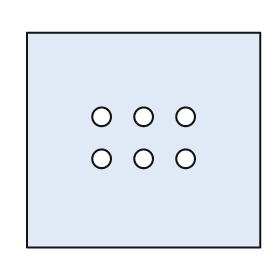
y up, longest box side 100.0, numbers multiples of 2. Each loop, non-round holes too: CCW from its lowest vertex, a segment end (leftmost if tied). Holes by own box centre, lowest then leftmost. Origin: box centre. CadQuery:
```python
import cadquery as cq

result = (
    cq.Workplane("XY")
    .moveTo(-50.0, -46.0)
    .lineTo(50.0, -46.0)
    .lineTo(50.0, 46.0)
    .lineTo(-50.0, 46.0)
    .close()
    .moveTo(-18.0, -8.0)
    .circle(4.0)
    .moveTo(0.0, -8.0)
    .circle(4.0)
    .moveTo(18.0, -8.0)
    .circle(4.0)
    .moveTo(-18.0, 10.0)
    .circle(4.0)
    .moveTo(0.0, 10.0)
    .circle(4.0)
    .moveTo(18.0, 10.0)
    .circle(4.0)
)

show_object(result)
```